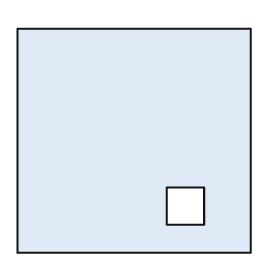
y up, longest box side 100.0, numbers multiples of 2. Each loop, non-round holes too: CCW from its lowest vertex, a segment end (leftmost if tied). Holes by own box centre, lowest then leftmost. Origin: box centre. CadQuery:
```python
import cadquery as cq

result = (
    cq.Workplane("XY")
    .moveTo(-50.0, -48.0)
    .lineTo(50.0, -48.0)
    .lineTo(50.0, 48.0)
    .lineTo(-50.0, 48.0)
    .close()
    .moveTo(14.0, -36.0)
    .lineTo(30.0, -36.0)
    .lineTo(30.0, -20.0)
    .lineTo(14.0, -20.0)
    .close()
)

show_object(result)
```